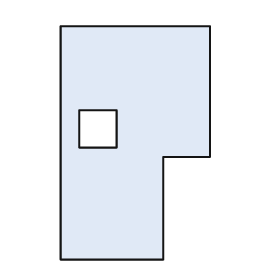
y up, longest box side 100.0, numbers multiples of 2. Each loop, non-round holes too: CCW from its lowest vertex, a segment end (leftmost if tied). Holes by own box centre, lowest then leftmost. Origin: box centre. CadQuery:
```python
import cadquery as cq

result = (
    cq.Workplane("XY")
    .moveTo(-32.0, -50.0)
    .lineTo(12.0, -50.0)
    .lineTo(12.0, -6.0)
    .lineTo(32.0, -6.0)
    .lineTo(32.0, 50.0)
    .lineTo(-32.0, 50.0)
    .close()
    .moveTo(-24.0, -2.0)
    .lineTo(-8.0, -2.0)
    .lineTo(-8.0, 14.0)
    .lineTo(-24.0, 14.0)
    .close()
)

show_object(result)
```